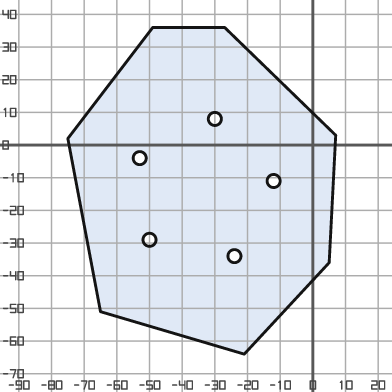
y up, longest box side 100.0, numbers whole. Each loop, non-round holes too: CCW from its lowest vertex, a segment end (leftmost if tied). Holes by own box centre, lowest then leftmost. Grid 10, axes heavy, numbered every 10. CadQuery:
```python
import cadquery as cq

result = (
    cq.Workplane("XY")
    .moveTo(-21.0, -64.0)
    .lineTo(5.0, -36.0)
    .lineTo(7.0, 3.0)
    .lineTo(-27.0, 36.0)
    .lineTo(-49.0, 36.0)
    .lineTo(-75.0, 2.0)
    .lineTo(-65.0, -51.0)
    .close()
    .moveTo(-24.0, -34.0)
    .circle(2.0)
    .moveTo(-50.0, -29.0)
    .circle(2.0)
    .moveTo(-12.0, -11.0)
    .circle(2.0)
    .moveTo(-53.0, -4.0)
    .circle(2.0)
    .moveTo(-30.0, 8.0)
    .circle(2.0)
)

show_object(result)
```